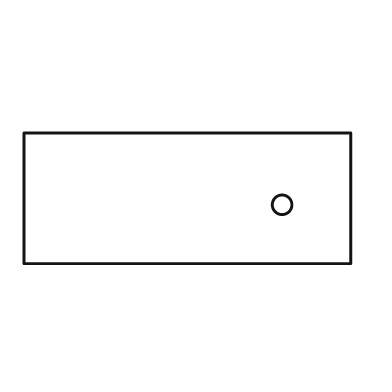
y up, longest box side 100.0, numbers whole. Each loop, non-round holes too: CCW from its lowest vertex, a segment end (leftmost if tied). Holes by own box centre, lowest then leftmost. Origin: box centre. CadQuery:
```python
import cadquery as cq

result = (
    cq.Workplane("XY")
    .moveTo(-50.0, -20.0)
    .lineTo(50.0, -20.0)
    .lineTo(50.0, 20.0)
    .lineTo(-50.0, 20.0)
    .close()
    .moveTo(29.0, -2.0)
    .circle(3.0)
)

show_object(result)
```